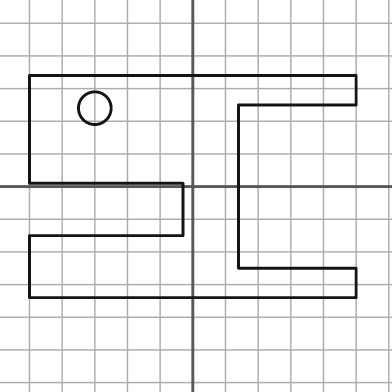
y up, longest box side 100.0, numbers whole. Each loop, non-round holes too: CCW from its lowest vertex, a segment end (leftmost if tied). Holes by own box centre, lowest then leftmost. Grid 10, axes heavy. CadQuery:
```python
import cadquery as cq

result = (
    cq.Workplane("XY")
    .moveTo(-50.0, -34.0)
    .lineTo(50.0, -34.0)
    .lineTo(50.0, -25.0)
    .lineTo(14.0, -25.0)
    .lineTo(14.0, 25.0)
    .lineTo(50.0, 25.0)
    .lineTo(50.0, 34.0)
    .lineTo(-50.0, 34.0)
    .lineTo(-50.0, 1.0)
    .lineTo(-3.0, 1.0)
    .lineTo(-3.0, -15.0)
    .lineTo(-50.0, -15.0)
    .close()
    .moveTo(-30.0, 24.0)
    .circle(5.0)
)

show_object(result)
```